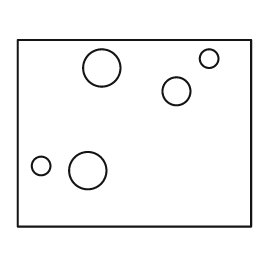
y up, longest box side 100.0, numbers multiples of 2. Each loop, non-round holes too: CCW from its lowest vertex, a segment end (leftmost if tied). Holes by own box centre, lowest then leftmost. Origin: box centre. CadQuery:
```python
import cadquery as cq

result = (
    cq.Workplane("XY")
    .moveTo(-50.0, -40.0)
    .lineTo(50.0, -40.0)
    .lineTo(50.0, 40.0)
    .lineTo(-50.0, 40.0)
    .close()
    .moveTo(-20.0, -16.0)
    .circle(8.0)
    .moveTo(-40.0, -14.0)
    .circle(4.0)
    .moveTo(18.0, 18.0)
    .circle(6.0)
    .moveTo(-14.0, 28.0)
    .circle(8.0)
    .moveTo(32.0, 32.0)
    .circle(4.0)
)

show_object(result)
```